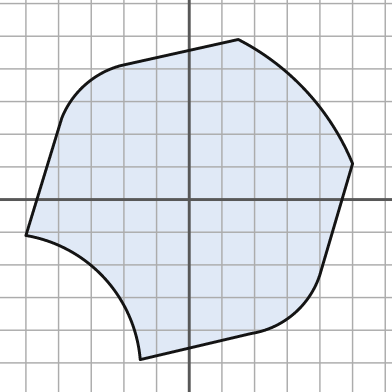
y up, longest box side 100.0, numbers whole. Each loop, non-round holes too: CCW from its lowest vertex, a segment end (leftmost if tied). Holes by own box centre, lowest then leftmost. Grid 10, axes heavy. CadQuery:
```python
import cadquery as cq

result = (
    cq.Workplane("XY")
    .moveTo(-15.0, -49.0)
    .lineTo(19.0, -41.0)
    .threePointArc((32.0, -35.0), (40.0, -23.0))
    .lineTo(50.0, 11.0)
    .threePointArc((36.0, 33.0), (15.0, 49.0))
    .lineTo(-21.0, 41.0)
    .threePointArc((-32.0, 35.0), (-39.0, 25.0))
    .lineTo(-50.0, -11.0)
    .threePointArc((-26.0, -24.0), (-15.0, -49.0))
    .close()
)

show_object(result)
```